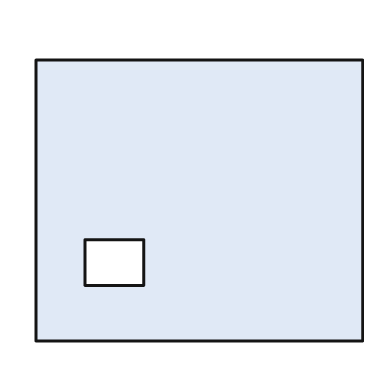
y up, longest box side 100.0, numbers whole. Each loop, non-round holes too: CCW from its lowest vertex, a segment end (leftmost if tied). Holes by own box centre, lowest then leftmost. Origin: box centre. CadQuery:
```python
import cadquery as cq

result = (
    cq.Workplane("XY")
    .moveTo(-50.0, -43.0)
    .lineTo(50.0, -43.0)
    .lineTo(50.0, 43.0)
    .lineTo(-50.0, 43.0)
    .close()
    .moveTo(-35.0, -26.0)
    .lineTo(-17.0, -26.0)
    .lineTo(-17.0, -12.0)
    .lineTo(-35.0, -12.0)
    .close()
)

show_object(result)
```